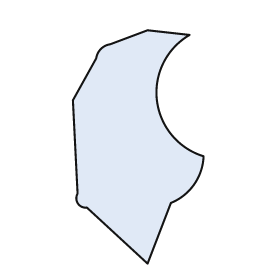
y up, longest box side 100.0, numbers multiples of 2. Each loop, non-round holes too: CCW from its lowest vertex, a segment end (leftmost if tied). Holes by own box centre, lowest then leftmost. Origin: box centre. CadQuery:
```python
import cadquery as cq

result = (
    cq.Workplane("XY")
    .moveTo(4.0, -50.0)
    .lineTo(14.0, -24.0)
    .threePointArc((24.0, -16.0), (28.0, -4.0))
    .threePointArc((8.0, 20.0), (22.0, 48.0))
    .lineTo(4.0, 50.0)
    .lineTo(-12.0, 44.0)
    .threePointArc((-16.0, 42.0), (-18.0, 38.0))
    .lineTo(-28.0, 20.0)
    .lineTo(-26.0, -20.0)
    .threePointArc((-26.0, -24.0), (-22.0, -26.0))
    .close()
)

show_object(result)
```